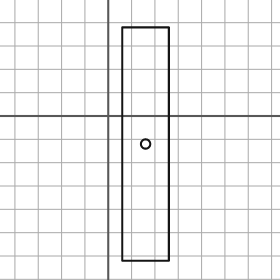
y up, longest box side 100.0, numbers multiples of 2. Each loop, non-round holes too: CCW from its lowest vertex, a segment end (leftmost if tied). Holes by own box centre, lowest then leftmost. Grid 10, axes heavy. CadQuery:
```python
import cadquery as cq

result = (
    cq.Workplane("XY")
    .moveTo(6.0, -62.0)
    .lineTo(26.0, -62.0)
    .lineTo(26.0, 38.0)
    .lineTo(6.0, 38.0)
    .close()
    .moveTo(16.0, -12.0)
    .circle(2.0)
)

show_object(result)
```